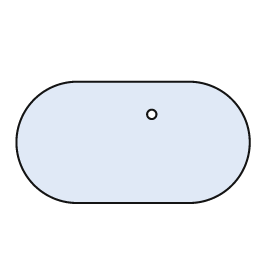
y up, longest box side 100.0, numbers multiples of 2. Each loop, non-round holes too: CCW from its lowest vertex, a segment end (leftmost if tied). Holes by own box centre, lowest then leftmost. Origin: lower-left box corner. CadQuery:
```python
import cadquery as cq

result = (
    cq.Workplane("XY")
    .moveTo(26.0, 0.0)
    .lineTo(74.0, 0.0)
    .threePointArc((100.0, 26.0), (74.0, 52.0))
    .lineTo(26.0, 52.0)
    .threePointArc((0.0, 26.0), (26.0, 0.0))
    .close()
    .moveTo(58.0, 38.0)
    .circle(2.0)
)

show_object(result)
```